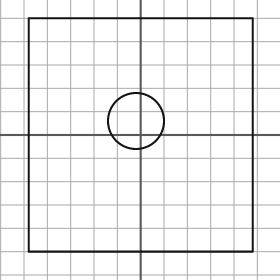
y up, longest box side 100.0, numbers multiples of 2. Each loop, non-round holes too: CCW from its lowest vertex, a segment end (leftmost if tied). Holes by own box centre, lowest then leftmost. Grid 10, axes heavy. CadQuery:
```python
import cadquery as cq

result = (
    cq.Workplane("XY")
    .moveTo(-48.0, -50.0)
    .lineTo(48.0, -50.0)
    .lineTo(48.0, 50.0)
    .lineTo(-48.0, 50.0)
    .close()
    .moveTo(-2.0, 6.0)
    .circle(12.0)
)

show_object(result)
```